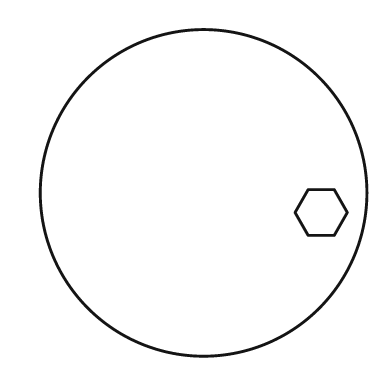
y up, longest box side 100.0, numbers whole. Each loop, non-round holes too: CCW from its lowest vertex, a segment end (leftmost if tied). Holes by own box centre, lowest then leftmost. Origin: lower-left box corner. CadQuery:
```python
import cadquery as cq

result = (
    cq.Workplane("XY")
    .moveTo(50.0, 50.0)
    .circle(50.0)
    .moveTo(82.0, 37.0)
    .lineTo(90.0, 37.0)
    .lineTo(94.0, 44.0)
    .lineTo(90.0, 51.0)
    .lineTo(82.0, 51.0)
    .lineTo(78.0, 44.0)
    .close()
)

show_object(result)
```